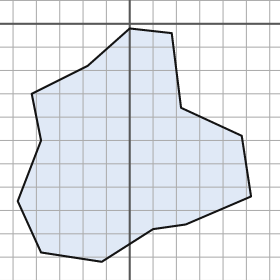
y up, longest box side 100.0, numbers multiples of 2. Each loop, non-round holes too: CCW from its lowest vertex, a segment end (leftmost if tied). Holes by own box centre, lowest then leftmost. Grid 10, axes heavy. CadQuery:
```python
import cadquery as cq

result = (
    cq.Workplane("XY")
    .moveTo(-12.0, -102.0)
    .lineTo(10.0, -88.0)
    .lineTo(24.0, -86.0)
    .lineTo(52.0, -74.0)
    .lineTo(48.0, -48.0)
    .lineTo(22.0, -36.0)
    .lineTo(18.0, -4.0)
    .lineTo(0.0, -2.0)
    .lineTo(-18.0, -18.0)
    .lineTo(-42.0, -30.0)
    .lineTo(-38.0, -50.0)
    .lineTo(-48.0, -76.0)
    .lineTo(-38.0, -98.0)
    .close()
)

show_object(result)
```